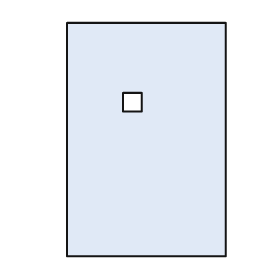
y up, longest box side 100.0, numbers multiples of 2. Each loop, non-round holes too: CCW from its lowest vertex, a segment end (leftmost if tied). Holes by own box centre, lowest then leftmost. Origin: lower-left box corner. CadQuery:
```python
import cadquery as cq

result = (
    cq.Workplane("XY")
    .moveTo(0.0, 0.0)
    .lineTo(68.0, 0.0)
    .lineTo(68.0, 100.0)
    .lineTo(0.0, 100.0)
    .close()
    .moveTo(24.0, 62.0)
    .lineTo(32.0, 62.0)
    .lineTo(32.0, 70.0)
    .lineTo(24.0, 70.0)
    .close()
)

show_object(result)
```